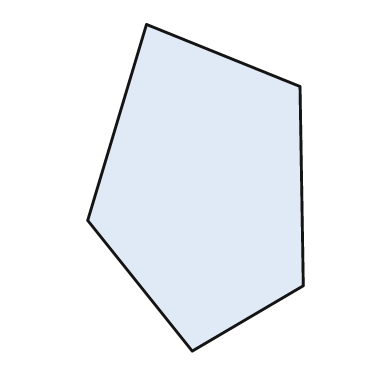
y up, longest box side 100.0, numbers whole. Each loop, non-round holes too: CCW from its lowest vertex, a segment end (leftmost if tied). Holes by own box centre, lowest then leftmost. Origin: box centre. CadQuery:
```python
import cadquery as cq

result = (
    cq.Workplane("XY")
    .moveTo(-1.0, -50.0)
    .lineTo(33.0, -30.0)
    .lineTo(32.0, 31.0)
    .lineTo(-15.0, 50.0)
    .lineTo(-33.0, -10.0)
    .close()
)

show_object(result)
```